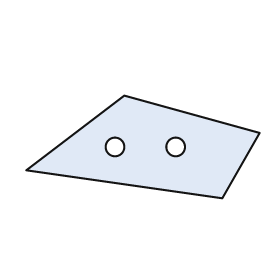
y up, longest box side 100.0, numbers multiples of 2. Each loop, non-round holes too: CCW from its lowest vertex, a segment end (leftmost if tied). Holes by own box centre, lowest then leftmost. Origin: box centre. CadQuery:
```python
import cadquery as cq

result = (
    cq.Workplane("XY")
    .moveTo(34.0, -22.0)
    .lineTo(50.0, 6.0)
    .lineTo(-8.0, 22.0)
    .lineTo(-50.0, -10.0)
    .close()
    .moveTo(-12.0, 0.0)
    .circle(4.0)
    .moveTo(14.0, 0.0)
    .circle(4.0)
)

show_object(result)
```